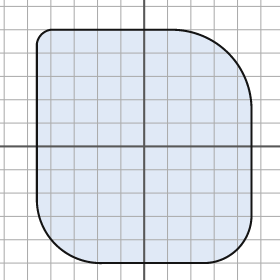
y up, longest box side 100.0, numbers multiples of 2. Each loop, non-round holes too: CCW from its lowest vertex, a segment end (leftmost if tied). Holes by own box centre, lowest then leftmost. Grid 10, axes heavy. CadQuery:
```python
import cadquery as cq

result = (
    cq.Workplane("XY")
    .moveTo(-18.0, -50.0)
    .lineTo(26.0, -50.0)
    .threePointArc((40.0, -44.0), (46.0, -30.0))
    .lineTo(46.0, 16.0)
    .threePointArc((36.0, 40.0), (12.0, 50.0))
    .lineTo(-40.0, 50.0)
    .threePointArc((-44.0, 48.0), (-46.0, 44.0))
    .lineTo(-46.0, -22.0)
    .threePointArc((-38.0, -42.0), (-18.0, -50.0))
    .close()
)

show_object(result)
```